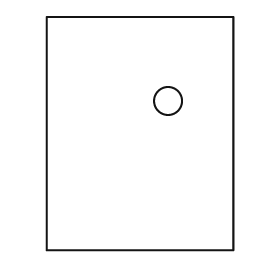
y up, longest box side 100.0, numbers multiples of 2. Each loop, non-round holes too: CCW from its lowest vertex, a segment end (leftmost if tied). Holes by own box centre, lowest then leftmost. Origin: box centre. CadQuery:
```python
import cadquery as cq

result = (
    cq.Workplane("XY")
    .moveTo(-40.0, -50.0)
    .lineTo(40.0, -50.0)
    .lineTo(40.0, 50.0)
    .lineTo(-40.0, 50.0)
    .close()
    .moveTo(12.0, 14.0)
    .circle(6.0)
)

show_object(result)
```